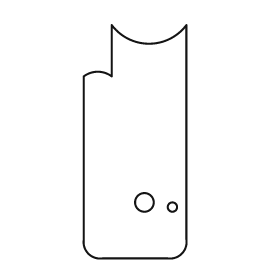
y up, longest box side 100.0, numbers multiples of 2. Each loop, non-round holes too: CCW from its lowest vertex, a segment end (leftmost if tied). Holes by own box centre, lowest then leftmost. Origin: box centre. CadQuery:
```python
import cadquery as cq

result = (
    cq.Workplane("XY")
    .moveTo(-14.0, -50.0)
    .lineTo(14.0, -50.0)
    .threePointArc((20.0, -48.0), (22.0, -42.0))
    .lineTo(22.0, 50.0)
    .threePointArc((6.0, 42.0), (-10.0, 50.0))
    .lineTo(-10.0, 28.0)
    .threePointArc((-16.0, 30.0), (-22.0, 28.0))
    .lineTo(-22.0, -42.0)
    .threePointArc((-20.0, -48.0), (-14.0, -50.0))
    .close()
    .moveTo(16.0, -28.0)
    .circle(2.0)
    .moveTo(4.0, -26.0)
    .circle(4.0)
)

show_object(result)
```